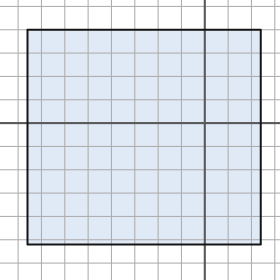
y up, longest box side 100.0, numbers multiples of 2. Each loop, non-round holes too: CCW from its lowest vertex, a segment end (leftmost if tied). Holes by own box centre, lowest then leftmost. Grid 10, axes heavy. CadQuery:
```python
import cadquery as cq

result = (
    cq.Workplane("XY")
    .moveTo(-76.0, -52.0)
    .lineTo(24.0, -52.0)
    .lineTo(24.0, 40.0)
    .lineTo(-76.0, 40.0)
    .close()
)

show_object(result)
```